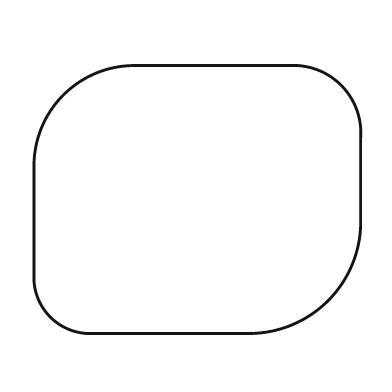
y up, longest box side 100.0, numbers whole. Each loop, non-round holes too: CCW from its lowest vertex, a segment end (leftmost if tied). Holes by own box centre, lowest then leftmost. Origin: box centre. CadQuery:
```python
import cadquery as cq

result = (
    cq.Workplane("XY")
    .moveTo(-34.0, -41.0)
    .lineTo(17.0, -41.0)
    .threePointArc((40.0, -31.0), (50.0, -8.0))
    .lineTo(50.0, 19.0)
    .threePointArc((44.0, 35.0), (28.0, 41.0))
    .lineTo(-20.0, 41.0)
    .threePointArc((-41.0, 32.0), (-50.0, 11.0))
    .lineTo(-50.0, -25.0)
    .threePointArc((-45.0, -36.0), (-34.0, -41.0))
    .close()
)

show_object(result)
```